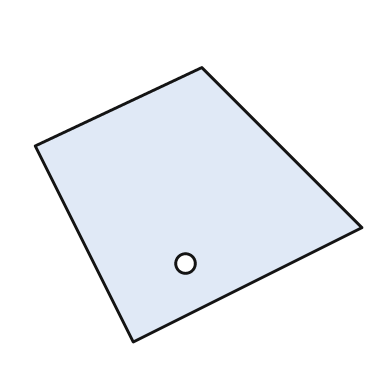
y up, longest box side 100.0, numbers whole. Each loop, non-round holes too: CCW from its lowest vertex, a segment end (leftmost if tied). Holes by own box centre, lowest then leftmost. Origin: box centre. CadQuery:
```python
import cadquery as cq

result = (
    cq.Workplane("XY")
    .moveTo(-20.0, -42.0)
    .lineTo(50.0, -7.0)
    .lineTo(1.0, 42.0)
    .lineTo(-50.0, 18.0)
    .close()
    .moveTo(-4.0, -18.0)
    .circle(3.0)
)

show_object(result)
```